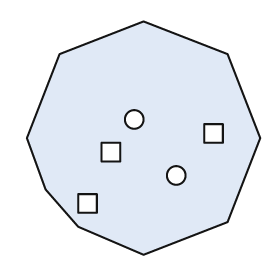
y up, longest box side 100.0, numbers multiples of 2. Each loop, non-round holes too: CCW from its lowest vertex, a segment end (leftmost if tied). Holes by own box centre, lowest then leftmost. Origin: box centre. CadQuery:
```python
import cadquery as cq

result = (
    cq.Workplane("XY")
    .moveTo(0.0, -50.0)
    .lineTo(36.0, -36.0)
    .lineTo(50.0, 0.0)
    .lineTo(36.0, 36.0)
    .lineTo(0.0, 50.0)
    .lineTo(-36.0, 36.0)
    .lineTo(-50.0, 0.0)
    .lineTo(-42.0, -22.0)
    .lineTo(-28.0, -38.0)
    .close()
    .moveTo(-28.0, -32.0)
    .lineTo(-20.0, -32.0)
    .lineTo(-20.0, -24.0)
    .lineTo(-28.0, -24.0)
    .close()
    .moveTo(14.0, -16.0)
    .circle(4.0)
    .moveTo(-18.0, -10.0)
    .lineTo(-10.0, -10.0)
    .lineTo(-10.0, -2.0)
    .lineTo(-18.0, -2.0)
    .close()
    .moveTo(26.0, -2.0)
    .lineTo(34.0, -2.0)
    .lineTo(34.0, 6.0)
    .lineTo(26.0, 6.0)
    .close()
    .moveTo(-4.0, 8.0)
    .circle(4.0)
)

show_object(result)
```